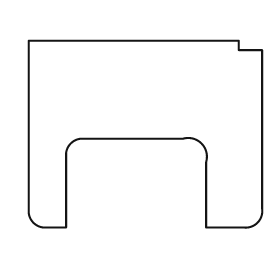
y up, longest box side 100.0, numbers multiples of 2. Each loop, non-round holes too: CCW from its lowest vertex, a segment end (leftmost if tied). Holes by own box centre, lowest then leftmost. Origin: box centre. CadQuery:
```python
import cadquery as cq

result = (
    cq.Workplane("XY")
    .moveTo(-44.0, -40.0)
    .lineTo(-34.0, -40.0)
    .lineTo(-34.0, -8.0)
    .threePointArc((-32.0, -4.0), (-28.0, -2.0))
    .lineTo(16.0, -2.0)
    .threePointArc((24.0, -4.0), (26.0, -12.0))
    .lineTo(26.0, -40.0)
    .lineTo(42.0, -40.0)
    .threePointArc((48.0, -38.0), (50.0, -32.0))
    .lineTo(50.0, 36.0)
    .lineTo(40.0, 36.0)
    .lineTo(40.0, 40.0)
    .lineTo(-50.0, 40.0)
    .lineTo(-50.0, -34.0)
    .threePointArc((-48.0, -38.0), (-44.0, -40.0))
    .close()
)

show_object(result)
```